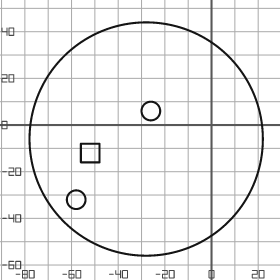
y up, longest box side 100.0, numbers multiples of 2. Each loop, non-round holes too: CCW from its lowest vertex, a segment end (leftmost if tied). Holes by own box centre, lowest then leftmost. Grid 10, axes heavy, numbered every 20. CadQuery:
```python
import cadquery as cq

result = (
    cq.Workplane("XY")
    .moveTo(-28.0, -6.0)
    .circle(50.0)
    .moveTo(-58.0, -32.0)
    .circle(4.0)
    .moveTo(-56.0, -16.0)
    .lineTo(-48.0, -16.0)
    .lineTo(-48.0, -8.0)
    .lineTo(-56.0, -8.0)
    .close()
    .moveTo(-26.0, 6.0)
    .circle(4.0)
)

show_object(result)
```